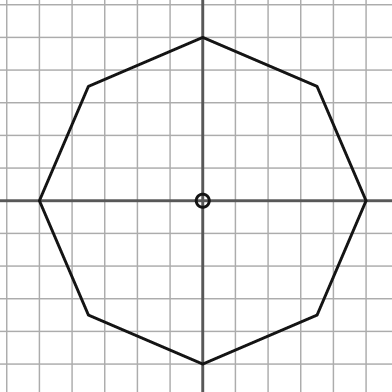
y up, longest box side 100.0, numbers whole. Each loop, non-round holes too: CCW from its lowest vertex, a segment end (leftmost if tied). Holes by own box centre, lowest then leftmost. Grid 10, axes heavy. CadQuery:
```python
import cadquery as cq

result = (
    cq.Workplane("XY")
    .moveTo(0.0, -50.0)
    .lineTo(35.0, -35.0)
    .lineTo(50.0, 0.0)
    .lineTo(35.0, 35.0)
    .lineTo(0.0, 50.0)
    .lineTo(-35.0, 35.0)
    .lineTo(-50.0, 0.0)
    .lineTo(-35.0, -35.0)
    .close()
    .moveTo(0.0, 0.0)
    .circle(2.0)
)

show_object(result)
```